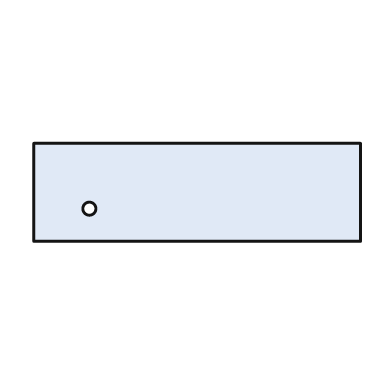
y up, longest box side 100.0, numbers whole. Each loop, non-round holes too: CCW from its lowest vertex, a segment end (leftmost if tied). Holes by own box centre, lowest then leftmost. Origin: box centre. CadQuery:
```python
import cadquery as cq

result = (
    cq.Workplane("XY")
    .moveTo(-50.0, -15.0)
    .lineTo(50.0, -15.0)
    .lineTo(50.0, 15.0)
    .lineTo(-50.0, 15.0)
    .close()
    .moveTo(-33.0, -5.0)
    .circle(2.0)
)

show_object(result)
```